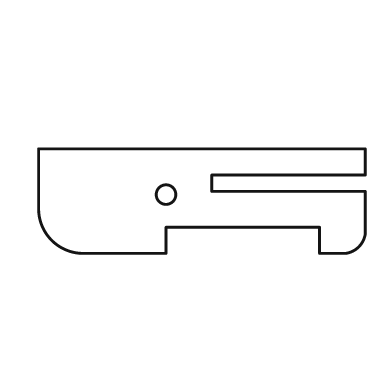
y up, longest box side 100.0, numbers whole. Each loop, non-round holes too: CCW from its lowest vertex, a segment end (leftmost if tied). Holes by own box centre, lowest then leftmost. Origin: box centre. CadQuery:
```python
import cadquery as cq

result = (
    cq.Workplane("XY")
    .moveTo(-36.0, -16.0)
    .lineTo(-11.0, -16.0)
    .lineTo(-11.0, -8.0)
    .lineTo(36.0, -8.0)
    .lineTo(36.0, -16.0)
    .lineTo(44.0, -16.0)
    .threePointArc((48.0, -14.0), (50.0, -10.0))
    .lineTo(50.0, 3.0)
    .lineTo(3.0, 3.0)
    .lineTo(3.0, 8.0)
    .lineTo(50.0, 8.0)
    .lineTo(50.0, 16.0)
    .lineTo(-50.0, 16.0)
    .lineTo(-50.0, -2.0)
    .threePointArc((-46.0, -12.0), (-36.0, -16.0))
    .close()
    .moveTo(-11.0, 2.0)
    .circle(3.0)
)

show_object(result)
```